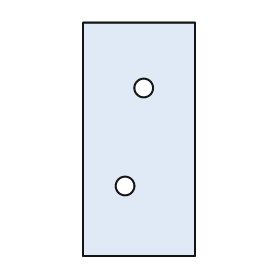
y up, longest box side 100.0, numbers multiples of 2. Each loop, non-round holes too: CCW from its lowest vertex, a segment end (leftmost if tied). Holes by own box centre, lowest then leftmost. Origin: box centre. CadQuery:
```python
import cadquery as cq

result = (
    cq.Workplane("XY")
    .moveTo(-24.0, -50.0)
    .lineTo(24.0, -50.0)
    .lineTo(24.0, 50.0)
    .lineTo(-24.0, 50.0)
    .close()
    .moveTo(-6.0, -20.0)
    .circle(4.0)
    .moveTo(2.0, 22.0)
    .circle(4.0)
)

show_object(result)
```